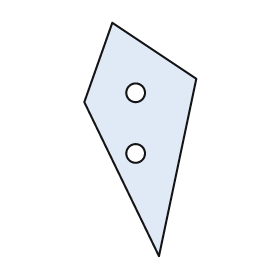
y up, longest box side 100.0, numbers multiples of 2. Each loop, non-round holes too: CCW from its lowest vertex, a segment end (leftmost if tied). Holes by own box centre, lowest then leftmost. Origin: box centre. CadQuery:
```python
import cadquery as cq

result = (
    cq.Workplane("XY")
    .moveTo(8.0, -50.0)
    .lineTo(24.0, 26.0)
    .lineTo(-12.0, 50.0)
    .lineTo(-24.0, 16.0)
    .close()
    .moveTo(-2.0, -6.0)
    .circle(4.0)
    .moveTo(-2.0, 20.0)
    .circle(4.0)
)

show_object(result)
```